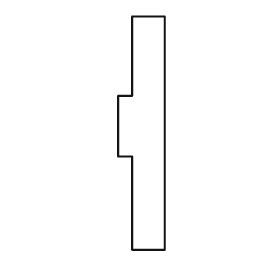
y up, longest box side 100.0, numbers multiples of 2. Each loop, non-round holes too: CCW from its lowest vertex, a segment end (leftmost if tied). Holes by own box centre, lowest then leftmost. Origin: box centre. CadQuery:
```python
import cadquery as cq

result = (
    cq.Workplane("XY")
    .moveTo(-4.0, -50.0)
    .lineTo(10.0, -50.0)
    .lineTo(10.0, 50.0)
    .lineTo(-4.0, 50.0)
    .lineTo(-4.0, 16.0)
    .lineTo(-10.0, 16.0)
    .lineTo(-10.0, -10.0)
    .lineTo(-4.0, -10.0)
    .close()
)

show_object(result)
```